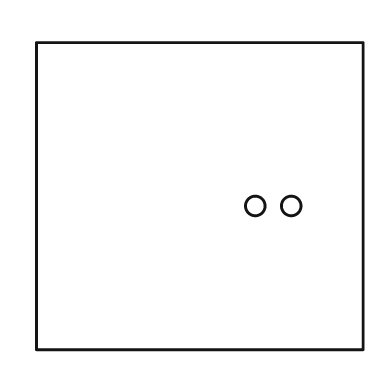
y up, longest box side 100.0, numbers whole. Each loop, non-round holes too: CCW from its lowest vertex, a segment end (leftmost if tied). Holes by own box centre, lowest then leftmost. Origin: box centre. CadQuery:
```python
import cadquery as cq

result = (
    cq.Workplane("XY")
    .moveTo(-50.0, -47.0)
    .lineTo(50.0, -47.0)
    .lineTo(50.0, 47.0)
    .lineTo(-50.0, 47.0)
    .close()
    .moveTo(17.0, -3.0)
    .circle(3.0)
    .moveTo(28.0, -3.0)
    .circle(3.0)
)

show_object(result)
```